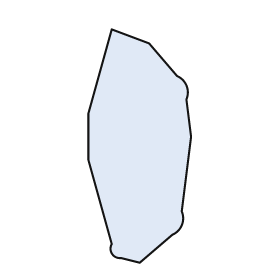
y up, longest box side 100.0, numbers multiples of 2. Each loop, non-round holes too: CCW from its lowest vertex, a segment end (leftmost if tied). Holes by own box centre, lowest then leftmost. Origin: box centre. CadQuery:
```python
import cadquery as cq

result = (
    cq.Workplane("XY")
    .moveTo(0.0, -50.0)
    .lineTo(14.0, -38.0)
    .threePointArc((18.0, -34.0), (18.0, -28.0))
    .lineTo(22.0, 4.0)
    .lineTo(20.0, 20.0)
    .threePointArc((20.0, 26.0), (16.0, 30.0))
    .lineTo(4.0, 44.0)
    .lineTo(-12.0, 50.0)
    .lineTo(-22.0, 14.0)
    .lineTo(-22.0, -6.0)
    .lineTo(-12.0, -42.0)
    .threePointArc((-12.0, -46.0), (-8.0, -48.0))
    .close()
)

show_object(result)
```